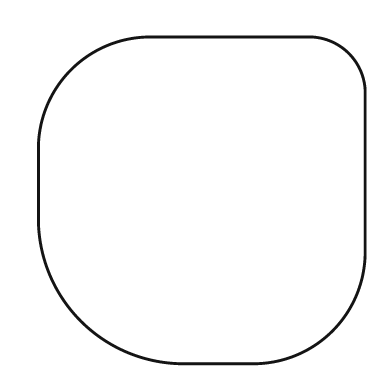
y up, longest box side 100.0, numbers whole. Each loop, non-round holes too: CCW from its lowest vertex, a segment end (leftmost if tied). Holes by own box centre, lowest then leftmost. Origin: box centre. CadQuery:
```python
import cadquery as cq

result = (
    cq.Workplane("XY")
    .moveTo(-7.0, -50.0)
    .lineTo(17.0, -50.0)
    .threePointArc((40.0, -40.0), (50.0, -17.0))
    .lineTo(50.0, 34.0)
    .threePointArc((45.0, 45.0), (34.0, 50.0))
    .lineTo(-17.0, 50.0)
    .threePointArc((-40.0, 40.0), (-50.0, 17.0))
    .lineTo(-50.0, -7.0)
    .threePointArc((-37.0, -37.0), (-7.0, -50.0))
    .close()
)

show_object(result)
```